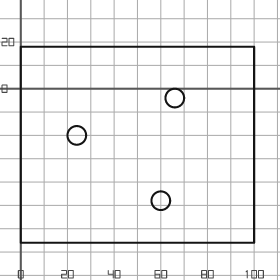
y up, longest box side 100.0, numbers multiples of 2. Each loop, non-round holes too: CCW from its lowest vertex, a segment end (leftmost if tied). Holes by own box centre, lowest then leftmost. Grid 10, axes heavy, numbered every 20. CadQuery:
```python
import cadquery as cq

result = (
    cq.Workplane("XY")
    .moveTo(0.0, -66.0)
    .lineTo(100.0, -66.0)
    .lineTo(100.0, 18.0)
    .lineTo(0.0, 18.0)
    .close()
    .moveTo(60.0, -48.0)
    .circle(4.0)
    .moveTo(24.0, -20.0)
    .circle(4.0)
    .moveTo(66.0, -4.0)
    .circle(4.0)
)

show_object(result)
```